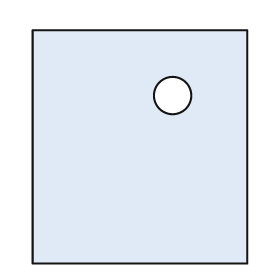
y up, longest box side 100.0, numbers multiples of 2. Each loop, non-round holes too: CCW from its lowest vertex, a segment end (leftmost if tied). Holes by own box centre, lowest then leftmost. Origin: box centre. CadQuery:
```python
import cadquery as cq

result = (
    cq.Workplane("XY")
    .moveTo(-46.0, -50.0)
    .lineTo(46.0, -50.0)
    .lineTo(46.0, 50.0)
    .lineTo(-46.0, 50.0)
    .close()
    .moveTo(14.0, 22.0)
    .circle(8.0)
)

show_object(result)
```